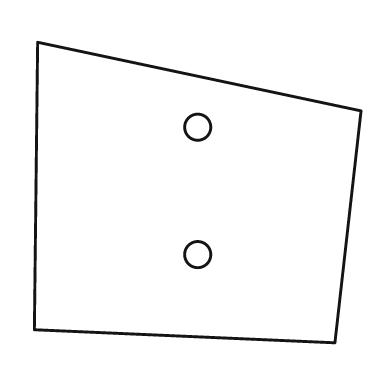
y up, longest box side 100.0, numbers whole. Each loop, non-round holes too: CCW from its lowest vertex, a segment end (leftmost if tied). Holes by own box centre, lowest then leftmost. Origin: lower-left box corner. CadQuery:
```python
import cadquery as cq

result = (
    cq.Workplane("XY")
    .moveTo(92.0, 0.0)
    .lineTo(100.0, 71.0)
    .lineTo(1.0, 92.0)
    .lineTo(0.0, 4.0)
    .close()
    .moveTo(50.0, 27.0)
    .circle(4.0)
    .moveTo(50.0, 66.0)
    .circle(4.0)
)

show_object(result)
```